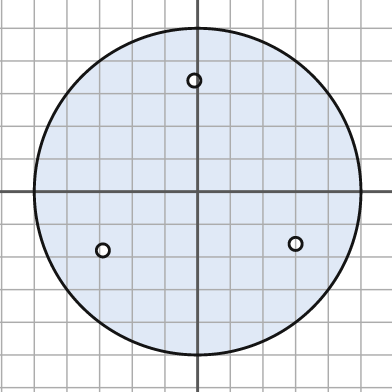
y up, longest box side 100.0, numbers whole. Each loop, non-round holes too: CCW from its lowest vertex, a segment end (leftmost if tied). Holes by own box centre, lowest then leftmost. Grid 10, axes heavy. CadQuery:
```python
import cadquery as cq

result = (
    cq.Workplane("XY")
    .moveTo(0.0, 0.0)
    .circle(50.0)
    .moveTo(-29.0, -18.0)
    .circle(2.0)
    .moveTo(30.0, -16.0)
    .circle(2.0)
    .moveTo(-1.0, 34.0)
    .circle(2.0)
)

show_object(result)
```